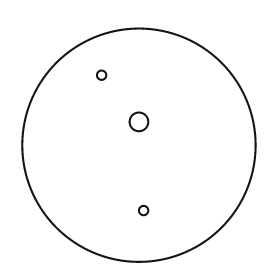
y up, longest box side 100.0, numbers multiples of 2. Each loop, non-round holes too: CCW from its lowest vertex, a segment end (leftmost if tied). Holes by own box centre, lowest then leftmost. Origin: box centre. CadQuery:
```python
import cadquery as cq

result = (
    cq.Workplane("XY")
    .moveTo(0.0, 0.0)
    .circle(50.0)
    .moveTo(2.0, -28.0)
    .circle(2.0)
    .moveTo(0.0, 10.0)
    .circle(4.0)
    .moveTo(-16.0, 30.0)
    .circle(2.0)
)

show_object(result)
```